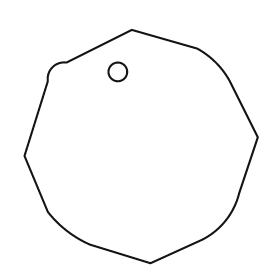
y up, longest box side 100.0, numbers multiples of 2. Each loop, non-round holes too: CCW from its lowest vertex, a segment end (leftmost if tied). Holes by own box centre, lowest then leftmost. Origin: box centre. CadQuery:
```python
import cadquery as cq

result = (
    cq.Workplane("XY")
    .moveTo(4.0, -50.0)
    .lineTo(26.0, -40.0)
    .threePointArc((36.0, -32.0), (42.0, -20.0))
    .lineTo(50.0, 4.0)
    .lineTo(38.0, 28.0)
    .threePointArc((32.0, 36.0), (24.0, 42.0))
    .lineTo(-4.0, 50.0)
    .lineTo(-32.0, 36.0)
    .threePointArc((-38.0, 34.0), (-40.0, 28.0))
    .lineTo(-50.0, -4.0)
    .lineTo(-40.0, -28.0)
    .threePointArc((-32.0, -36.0), (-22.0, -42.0))
    .close()
    .moveTo(-10.0, 32.0)
    .circle(4.0)
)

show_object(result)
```